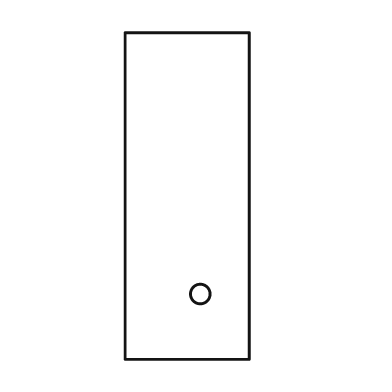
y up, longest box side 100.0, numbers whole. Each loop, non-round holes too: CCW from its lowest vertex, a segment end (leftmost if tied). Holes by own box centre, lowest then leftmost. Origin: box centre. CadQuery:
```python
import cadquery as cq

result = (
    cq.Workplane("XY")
    .moveTo(-19.0, -50.0)
    .lineTo(19.0, -50.0)
    .lineTo(19.0, 50.0)
    .lineTo(-19.0, 50.0)
    .close()
    .moveTo(4.0, -30.0)
    .circle(3.0)
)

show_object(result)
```